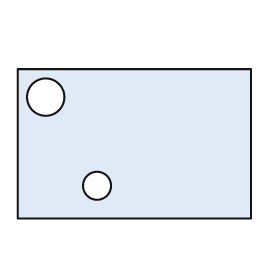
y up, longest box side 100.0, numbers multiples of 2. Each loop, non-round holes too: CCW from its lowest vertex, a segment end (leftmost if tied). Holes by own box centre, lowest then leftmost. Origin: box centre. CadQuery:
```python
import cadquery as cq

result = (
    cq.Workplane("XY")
    .moveTo(-50.0, -32.0)
    .lineTo(50.0, -32.0)
    .lineTo(50.0, 32.0)
    .lineTo(-50.0, 32.0)
    .close()
    .moveTo(-16.0, -18.0)
    .circle(6.0)
    .moveTo(-38.0, 20.0)
    .circle(8.0)
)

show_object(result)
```